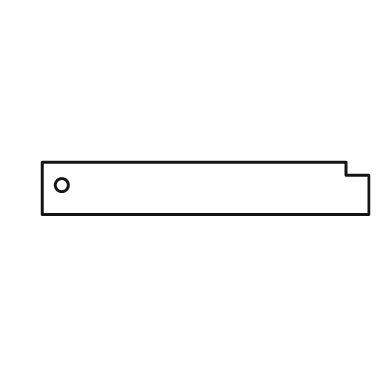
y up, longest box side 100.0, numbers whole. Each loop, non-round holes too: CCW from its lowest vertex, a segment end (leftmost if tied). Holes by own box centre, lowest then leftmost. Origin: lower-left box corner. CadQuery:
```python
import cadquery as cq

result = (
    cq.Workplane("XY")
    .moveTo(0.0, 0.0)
    .lineTo(100.0, 0.0)
    .lineTo(100.0, 12.0)
    .lineTo(93.0, 12.0)
    .lineTo(93.0, 16.0)
    .lineTo(0.0, 16.0)
    .close()
    .moveTo(6.0, 9.0)
    .circle(2.0)
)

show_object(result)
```